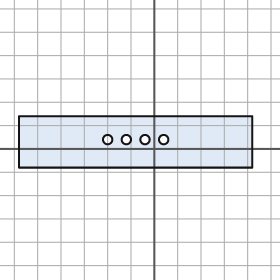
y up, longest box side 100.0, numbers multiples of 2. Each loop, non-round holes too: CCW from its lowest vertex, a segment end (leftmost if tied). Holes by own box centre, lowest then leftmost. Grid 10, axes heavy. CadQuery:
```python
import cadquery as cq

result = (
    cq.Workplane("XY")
    .moveTo(-58.0, -8.0)
    .lineTo(42.0, -8.0)
    .lineTo(42.0, 14.0)
    .lineTo(-58.0, 14.0)
    .close()
    .moveTo(-20.0, 4.0)
    .circle(2.0)
    .moveTo(-12.0, 4.0)
    .circle(2.0)
    .moveTo(-4.0, 4.0)
    .circle(2.0)
    .moveTo(4.0, 4.0)
    .circle(2.0)
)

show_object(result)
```